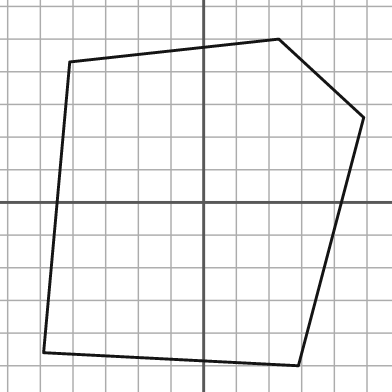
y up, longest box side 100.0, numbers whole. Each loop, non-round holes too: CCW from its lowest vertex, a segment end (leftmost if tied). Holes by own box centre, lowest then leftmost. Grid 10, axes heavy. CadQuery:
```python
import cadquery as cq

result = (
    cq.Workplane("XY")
    .moveTo(29.0, -50.0)
    .lineTo(49.0, 26.0)
    .lineTo(23.0, 50.0)
    .lineTo(-41.0, 43.0)
    .lineTo(-49.0, -46.0)
    .close()
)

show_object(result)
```